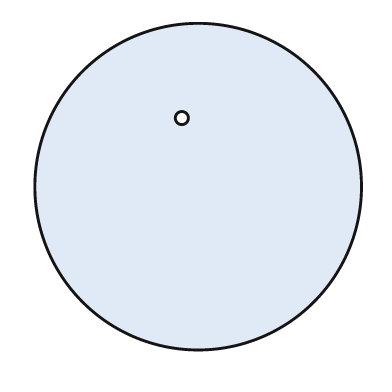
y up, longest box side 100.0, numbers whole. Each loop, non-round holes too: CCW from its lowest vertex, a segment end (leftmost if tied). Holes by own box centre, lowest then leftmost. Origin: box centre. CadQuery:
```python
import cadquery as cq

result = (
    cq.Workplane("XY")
    .moveTo(0.0, 0.0)
    .circle(50.0)
    .moveTo(-5.0, 21.0)
    .circle(2.0)
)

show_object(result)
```